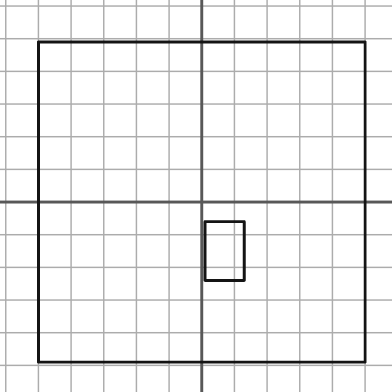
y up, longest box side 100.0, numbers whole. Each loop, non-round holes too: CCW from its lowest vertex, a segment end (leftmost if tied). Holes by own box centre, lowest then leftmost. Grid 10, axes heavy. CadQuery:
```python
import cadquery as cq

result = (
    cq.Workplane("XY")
    .moveTo(-50.0, -49.0)
    .lineTo(50.0, -49.0)
    .lineTo(50.0, 49.0)
    .lineTo(-50.0, 49.0)
    .close()
    .moveTo(1.0, -24.0)
    .lineTo(13.0, -24.0)
    .lineTo(13.0, -6.0)
    .lineTo(1.0, -6.0)
    .close()
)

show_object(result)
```